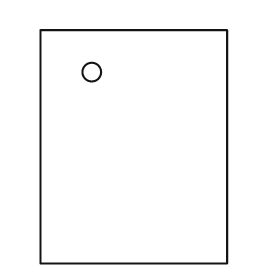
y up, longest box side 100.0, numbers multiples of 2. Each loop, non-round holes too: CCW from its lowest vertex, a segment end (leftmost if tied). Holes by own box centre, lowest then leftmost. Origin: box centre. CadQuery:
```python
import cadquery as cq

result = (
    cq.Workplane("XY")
    .moveTo(-40.0, -50.0)
    .lineTo(40.0, -50.0)
    .lineTo(40.0, 50.0)
    .lineTo(-40.0, 50.0)
    .close()
    .moveTo(-18.0, 32.0)
    .circle(4.0)
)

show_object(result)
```